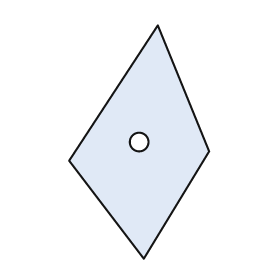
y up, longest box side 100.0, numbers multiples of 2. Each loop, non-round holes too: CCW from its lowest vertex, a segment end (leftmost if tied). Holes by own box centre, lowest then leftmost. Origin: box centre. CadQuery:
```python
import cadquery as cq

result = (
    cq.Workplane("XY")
    .moveTo(2.0, -50.0)
    .lineTo(30.0, -4.0)
    .lineTo(8.0, 50.0)
    .lineTo(-30.0, -8.0)
    .close()
    .moveTo(0.0, 0.0)
    .circle(4.0)
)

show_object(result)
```